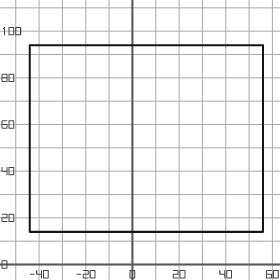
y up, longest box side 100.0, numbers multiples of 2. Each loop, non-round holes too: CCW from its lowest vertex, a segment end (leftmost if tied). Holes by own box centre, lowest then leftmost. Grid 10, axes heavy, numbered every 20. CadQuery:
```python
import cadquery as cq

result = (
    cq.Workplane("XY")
    .moveTo(-44.0, 14.0)
    .lineTo(56.0, 14.0)
    .lineTo(56.0, 94.0)
    .lineTo(-44.0, 94.0)
    .close()
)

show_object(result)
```